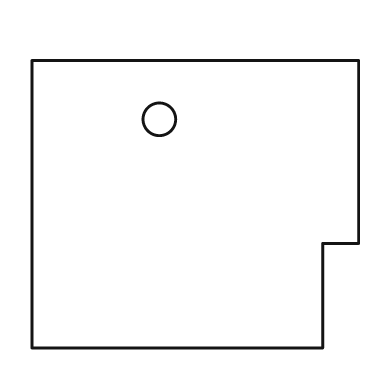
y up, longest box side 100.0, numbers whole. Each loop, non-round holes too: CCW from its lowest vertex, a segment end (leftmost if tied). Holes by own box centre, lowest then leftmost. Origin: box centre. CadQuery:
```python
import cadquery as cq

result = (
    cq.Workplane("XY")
    .moveTo(-50.0, -44.0)
    .lineTo(39.0, -44.0)
    .lineTo(39.0, -12.0)
    .lineTo(50.0, -12.0)
    .lineTo(50.0, 44.0)
    .lineTo(-50.0, 44.0)
    .close()
    .moveTo(-11.0, 26.0)
    .circle(5.0)
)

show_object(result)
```